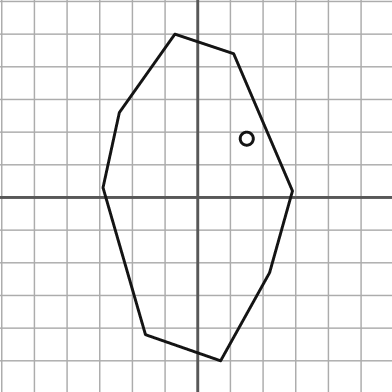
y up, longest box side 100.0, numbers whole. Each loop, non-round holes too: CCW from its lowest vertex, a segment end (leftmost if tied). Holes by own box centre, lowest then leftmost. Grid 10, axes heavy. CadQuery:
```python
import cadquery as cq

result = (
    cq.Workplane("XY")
    .moveTo(7.0, -50.0)
    .lineTo(22.0, -23.0)
    .lineTo(29.0, 2.0)
    .lineTo(11.0, 44.0)
    .lineTo(-7.0, 50.0)
    .lineTo(-24.0, 26.0)
    .lineTo(-29.0, 3.0)
    .lineTo(-16.0, -42.0)
    .close()
    .moveTo(15.0, 18.0)
    .circle(2.0)
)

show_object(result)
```